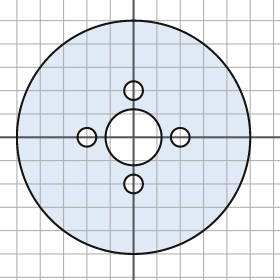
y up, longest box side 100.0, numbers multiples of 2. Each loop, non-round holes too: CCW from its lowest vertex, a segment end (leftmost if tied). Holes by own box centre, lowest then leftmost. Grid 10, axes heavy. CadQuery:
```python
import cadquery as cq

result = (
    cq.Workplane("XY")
    .moveTo(0.0, 0.0)
    .circle(50.0)
    .moveTo(0.0, -20.0)
    .circle(4.0)
    .moveTo(-20.0, 0.0)
    .circle(4.0)
    .moveTo(0.0, 0.0)
    .circle(12.0)
    .moveTo(20.0, 0.0)
    .circle(4.0)
    .moveTo(0.0, 20.0)
    .circle(4.0)
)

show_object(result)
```